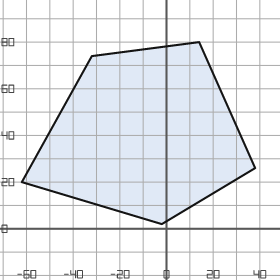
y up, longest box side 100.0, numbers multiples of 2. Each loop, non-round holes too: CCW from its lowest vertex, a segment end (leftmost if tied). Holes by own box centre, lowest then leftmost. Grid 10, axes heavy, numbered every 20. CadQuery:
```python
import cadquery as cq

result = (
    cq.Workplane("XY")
    .moveTo(-2.0, 2.0)
    .lineTo(38.0, 26.0)
    .lineTo(14.0, 80.0)
    .lineTo(-32.0, 74.0)
    .lineTo(-62.0, 20.0)
    .close()
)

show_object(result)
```